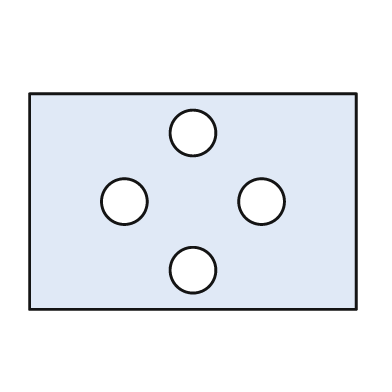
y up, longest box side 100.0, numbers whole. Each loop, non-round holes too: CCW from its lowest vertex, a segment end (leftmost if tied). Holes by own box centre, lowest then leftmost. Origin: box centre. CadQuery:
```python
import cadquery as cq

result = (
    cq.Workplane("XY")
    .moveTo(-50.0, -33.0)
    .lineTo(50.0, -33.0)
    .lineTo(50.0, 33.0)
    .lineTo(-50.0, 33.0)
    .close()
    .moveTo(0.0, -21.0)
    .circle(7.0)
    .moveTo(-21.0, 0.0)
    .circle(7.0)
    .moveTo(21.0, 0.0)
    .circle(7.0)
    .moveTo(0.0, 21.0)
    .circle(7.0)
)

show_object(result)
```